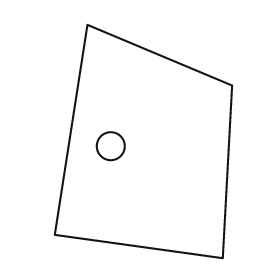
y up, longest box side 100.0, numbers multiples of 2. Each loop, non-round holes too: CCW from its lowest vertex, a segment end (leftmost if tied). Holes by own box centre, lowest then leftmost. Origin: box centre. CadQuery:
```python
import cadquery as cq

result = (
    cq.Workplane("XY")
    .moveTo(34.0, -50.0)
    .lineTo(38.0, 24.0)
    .lineTo(-24.0, 50.0)
    .lineTo(-38.0, -40.0)
    .close()
    .moveTo(-14.0, -2.0)
    .circle(6.0)
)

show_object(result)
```